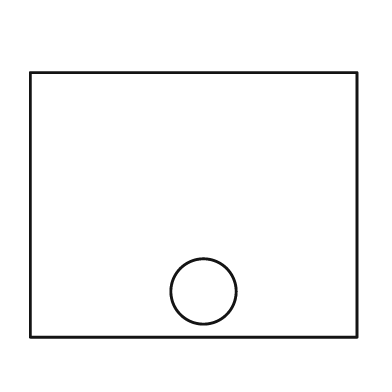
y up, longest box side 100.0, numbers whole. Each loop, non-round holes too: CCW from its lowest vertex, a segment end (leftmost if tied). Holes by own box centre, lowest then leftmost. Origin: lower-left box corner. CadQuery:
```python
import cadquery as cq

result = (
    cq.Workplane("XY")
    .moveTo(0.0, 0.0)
    .lineTo(100.0, 0.0)
    .lineTo(100.0, 81.0)
    .lineTo(0.0, 81.0)
    .close()
    .moveTo(53.0, 14.0)
    .circle(10.0)
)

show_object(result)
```